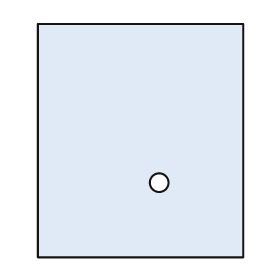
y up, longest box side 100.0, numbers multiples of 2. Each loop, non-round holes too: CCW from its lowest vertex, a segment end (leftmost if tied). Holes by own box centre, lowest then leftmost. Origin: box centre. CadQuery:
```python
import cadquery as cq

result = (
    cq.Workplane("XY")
    .moveTo(-44.0, -50.0)
    .lineTo(44.0, -50.0)
    .lineTo(44.0, 50.0)
    .lineTo(-44.0, 50.0)
    .close()
    .moveTo(8.0, -18.0)
    .circle(4.0)
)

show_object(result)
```